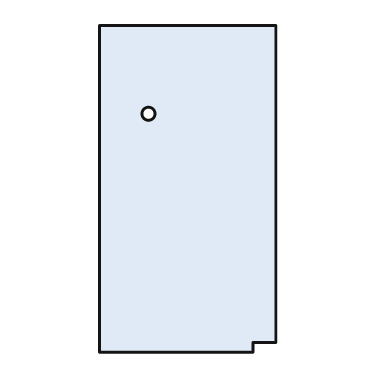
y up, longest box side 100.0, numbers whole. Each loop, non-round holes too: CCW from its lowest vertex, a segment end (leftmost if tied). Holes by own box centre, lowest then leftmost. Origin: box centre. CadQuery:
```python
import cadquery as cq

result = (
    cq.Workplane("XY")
    .moveTo(-27.0, -50.0)
    .lineTo(20.0, -50.0)
    .lineTo(20.0, -47.0)
    .lineTo(27.0, -47.0)
    .lineTo(27.0, 50.0)
    .lineTo(-27.0, 50.0)
    .close()
    .moveTo(-12.0, 23.0)
    .circle(2.0)
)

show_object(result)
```